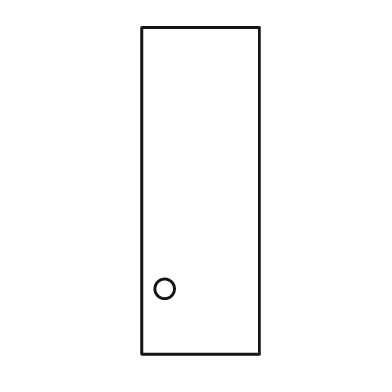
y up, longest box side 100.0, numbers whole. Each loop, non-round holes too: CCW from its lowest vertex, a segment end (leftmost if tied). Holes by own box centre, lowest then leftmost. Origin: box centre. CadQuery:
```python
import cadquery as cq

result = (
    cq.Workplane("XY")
    .moveTo(-18.0, -50.0)
    .lineTo(18.0, -50.0)
    .lineTo(18.0, 50.0)
    .lineTo(-18.0, 50.0)
    .close()
    .moveTo(-11.0, -30.0)
    .circle(3.0)
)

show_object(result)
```